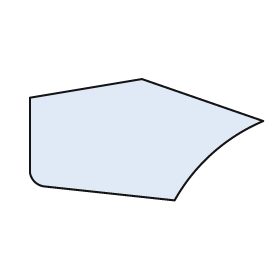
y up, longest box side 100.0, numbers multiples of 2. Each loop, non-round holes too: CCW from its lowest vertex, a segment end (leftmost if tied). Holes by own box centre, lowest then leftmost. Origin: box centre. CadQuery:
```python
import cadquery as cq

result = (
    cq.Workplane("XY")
    .moveTo(12.0, -26.0)
    .threePointArc((28.0, -6.0), (50.0, 8.0))
    .lineTo(-2.0, 26.0)
    .lineTo(-50.0, 18.0)
    .lineTo(-50.0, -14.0)
    .threePointArc((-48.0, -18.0), (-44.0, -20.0))
    .close()
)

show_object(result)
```